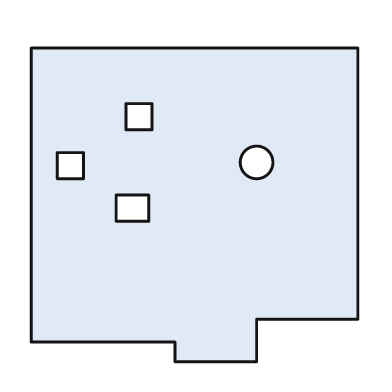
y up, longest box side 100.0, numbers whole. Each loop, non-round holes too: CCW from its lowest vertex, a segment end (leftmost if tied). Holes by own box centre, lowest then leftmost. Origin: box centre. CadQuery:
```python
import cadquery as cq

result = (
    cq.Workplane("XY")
    .moveTo(-6.0, -48.0)
    .lineTo(19.0, -48.0)
    .lineTo(19.0, -35.0)
    .lineTo(50.0, -35.0)
    .lineTo(50.0, 48.0)
    .lineTo(-50.0, 48.0)
    .lineTo(-50.0, -42.0)
    .lineTo(-6.0, -42.0)
    .close()
    .moveTo(-24.0, -5.0)
    .lineTo(-14.0, -5.0)
    .lineTo(-14.0, 3.0)
    .lineTo(-24.0, 3.0)
    .close()
    .moveTo(-42.0, 8.0)
    .lineTo(-34.0, 8.0)
    .lineTo(-34.0, 16.0)
    .lineTo(-42.0, 16.0)
    .close()
    .moveTo(19.0, 13.0)
    .circle(5.0)
    .moveTo(-21.0, 23.0)
    .lineTo(-13.0, 23.0)
    .lineTo(-13.0, 31.0)
    .lineTo(-21.0, 31.0)
    .close()
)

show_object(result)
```